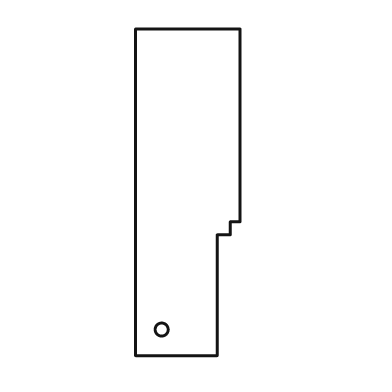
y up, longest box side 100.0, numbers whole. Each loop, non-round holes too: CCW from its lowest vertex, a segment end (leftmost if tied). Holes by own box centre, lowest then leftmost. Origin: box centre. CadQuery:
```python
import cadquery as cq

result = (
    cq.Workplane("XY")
    .moveTo(-16.0, -50.0)
    .lineTo(9.0, -50.0)
    .lineTo(9.0, -13.0)
    .lineTo(13.0, -13.0)
    .lineTo(13.0, -9.0)
    .lineTo(16.0, -9.0)
    .lineTo(16.0, 50.0)
    .lineTo(-16.0, 50.0)
    .close()
    .moveTo(-8.0, -42.0)
    .circle(2.0)
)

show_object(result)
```